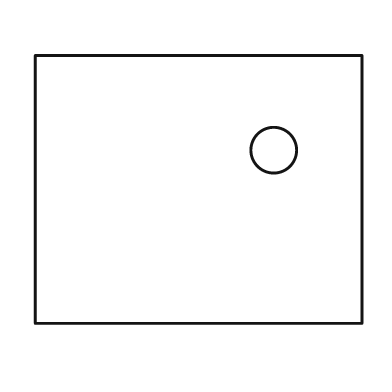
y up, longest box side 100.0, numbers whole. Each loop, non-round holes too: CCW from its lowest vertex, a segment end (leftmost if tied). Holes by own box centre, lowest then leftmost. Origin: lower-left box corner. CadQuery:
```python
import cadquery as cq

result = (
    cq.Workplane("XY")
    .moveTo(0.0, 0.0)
    .lineTo(100.0, 0.0)
    .lineTo(100.0, 82.0)
    .lineTo(0.0, 82.0)
    .close()
    .moveTo(73.0, 53.0)
    .circle(7.0)
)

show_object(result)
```